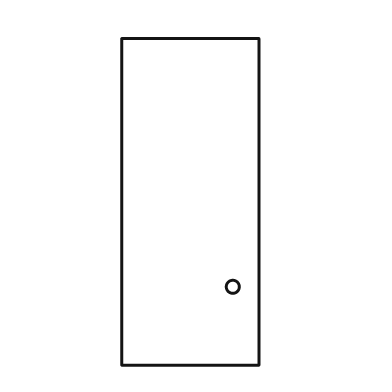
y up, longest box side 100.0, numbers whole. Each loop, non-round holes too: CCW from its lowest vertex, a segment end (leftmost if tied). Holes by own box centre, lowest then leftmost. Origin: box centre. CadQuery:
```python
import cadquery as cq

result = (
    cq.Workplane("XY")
    .moveTo(-21.0, -50.0)
    .lineTo(21.0, -50.0)
    .lineTo(21.0, 50.0)
    .lineTo(-21.0, 50.0)
    .close()
    .moveTo(13.0, -26.0)
    .circle(2.0)
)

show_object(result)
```